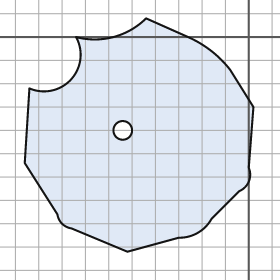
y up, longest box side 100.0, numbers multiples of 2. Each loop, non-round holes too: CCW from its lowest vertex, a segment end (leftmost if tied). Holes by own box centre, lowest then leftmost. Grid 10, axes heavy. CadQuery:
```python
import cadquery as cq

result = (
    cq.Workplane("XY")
    .moveTo(-52.0, -92.0)
    .lineTo(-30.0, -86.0)
    .threePointArc((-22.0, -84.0), (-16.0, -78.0))
    .lineTo(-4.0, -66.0)
    .threePointArc((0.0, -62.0), (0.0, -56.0))
    .lineTo(2.0, -30.0)
    .lineTo(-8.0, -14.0)
    .threePointArc((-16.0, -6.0), (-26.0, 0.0))
    .lineTo(-44.0, 8.0)
    .threePointArc((-58.0, 0.0), (-74.0, 0.0))
    .threePointArc((-76.0, -18.0), (-94.0, -22.0))
    .lineTo(-96.0, -54.0)
    .lineTo(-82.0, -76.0)
    .threePointArc((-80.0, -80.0), (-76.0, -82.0))
    .close()
    .moveTo(-54.0, -40.0)
    .circle(4.0)
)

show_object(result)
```